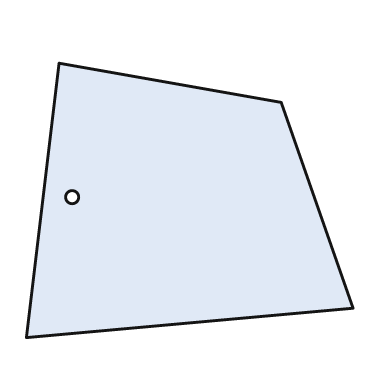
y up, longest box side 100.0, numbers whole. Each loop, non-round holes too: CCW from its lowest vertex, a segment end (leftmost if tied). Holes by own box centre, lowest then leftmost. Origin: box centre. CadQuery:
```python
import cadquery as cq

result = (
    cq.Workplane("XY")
    .moveTo(-50.0, -42.0)
    .lineTo(50.0, -33.0)
    .lineTo(28.0, 30.0)
    .lineTo(-40.0, 42.0)
    .close()
    .moveTo(-36.0, 1.0)
    .circle(2.0)
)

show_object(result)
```